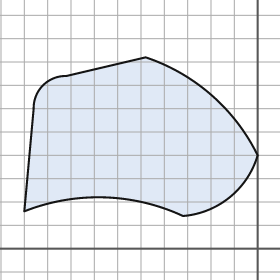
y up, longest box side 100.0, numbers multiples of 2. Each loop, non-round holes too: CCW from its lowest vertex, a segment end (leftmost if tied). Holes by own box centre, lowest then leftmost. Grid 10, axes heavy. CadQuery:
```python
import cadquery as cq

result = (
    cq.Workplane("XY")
    .moveTo(-32.0, 14.0)
    .threePointArc((-12.0, 22.0), (0.0, 40.0))
    .threePointArc((-20.0, 66.0), (-48.0, 82.0))
    .lineTo(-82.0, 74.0)
    .threePointArc((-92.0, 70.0), (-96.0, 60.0))
    .lineTo(-100.0, 16.0)
    .threePointArc((-66.0, 22.0), (-32.0, 14.0))
    .close()
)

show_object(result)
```